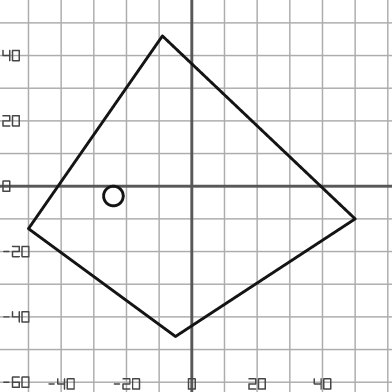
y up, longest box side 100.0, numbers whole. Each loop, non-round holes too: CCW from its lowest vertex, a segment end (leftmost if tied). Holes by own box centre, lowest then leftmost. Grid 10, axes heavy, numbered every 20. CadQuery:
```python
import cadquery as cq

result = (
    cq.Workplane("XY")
    .moveTo(-5.0, -46.0)
    .lineTo(50.0, -10.0)
    .lineTo(-9.0, 46.0)
    .lineTo(-50.0, -13.0)
    .close()
    .moveTo(-24.0, -3.0)
    .circle(3.0)
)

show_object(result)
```